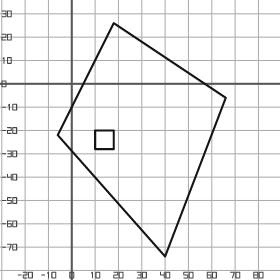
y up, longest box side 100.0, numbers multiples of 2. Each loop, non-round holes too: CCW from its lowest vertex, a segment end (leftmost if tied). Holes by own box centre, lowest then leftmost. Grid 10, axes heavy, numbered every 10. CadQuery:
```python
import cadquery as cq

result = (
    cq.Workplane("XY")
    .moveTo(40.0, -74.0)
    .lineTo(66.0, -6.0)
    .lineTo(18.0, 26.0)
    .lineTo(-6.0, -22.0)
    .close()
    .moveTo(10.0, -28.0)
    .lineTo(18.0, -28.0)
    .lineTo(18.0, -20.0)
    .lineTo(10.0, -20.0)
    .close()
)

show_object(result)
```